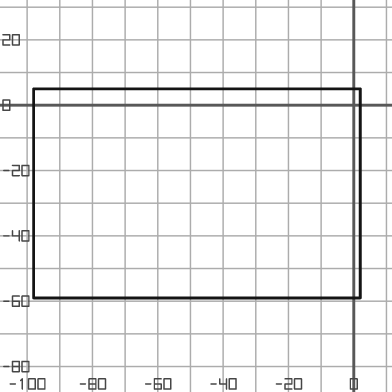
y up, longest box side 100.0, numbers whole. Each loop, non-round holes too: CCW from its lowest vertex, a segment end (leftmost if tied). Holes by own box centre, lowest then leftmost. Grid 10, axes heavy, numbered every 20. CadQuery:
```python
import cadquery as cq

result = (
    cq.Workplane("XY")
    .moveTo(-98.0, -59.0)
    .lineTo(2.0, -59.0)
    .lineTo(2.0, 5.0)
    .lineTo(-98.0, 5.0)
    .close()
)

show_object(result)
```